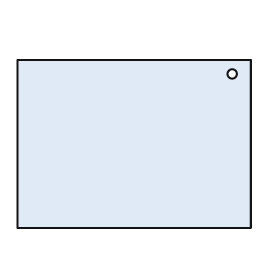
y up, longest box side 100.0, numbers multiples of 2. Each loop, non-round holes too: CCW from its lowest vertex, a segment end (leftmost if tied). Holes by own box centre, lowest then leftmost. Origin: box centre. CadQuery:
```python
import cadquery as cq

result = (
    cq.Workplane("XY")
    .moveTo(-50.0, -36.0)
    .lineTo(50.0, -36.0)
    .lineTo(50.0, 36.0)
    .lineTo(-50.0, 36.0)
    .close()
    .moveTo(42.0, 30.0)
    .circle(2.0)
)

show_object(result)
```